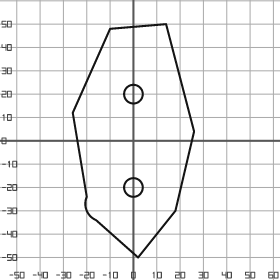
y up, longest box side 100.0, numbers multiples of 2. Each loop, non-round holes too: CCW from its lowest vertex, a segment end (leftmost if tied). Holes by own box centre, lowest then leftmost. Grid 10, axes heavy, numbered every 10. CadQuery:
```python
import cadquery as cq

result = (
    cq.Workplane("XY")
    .moveTo(2.0, -50.0)
    .lineTo(18.0, -30.0)
    .lineTo(26.0, 4.0)
    .lineTo(14.0, 50.0)
    .lineTo(-10.0, 48.0)
    .lineTo(-26.0, 12.0)
    .lineTo(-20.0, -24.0)
    .threePointArc((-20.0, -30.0), (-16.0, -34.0))
    .close()
    .moveTo(0.0, -20.0)
    .circle(4.0)
    .moveTo(0.0, 20.0)
    .circle(4.0)
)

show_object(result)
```